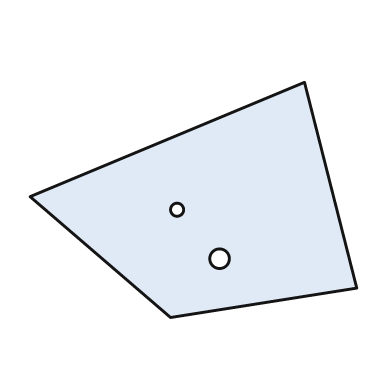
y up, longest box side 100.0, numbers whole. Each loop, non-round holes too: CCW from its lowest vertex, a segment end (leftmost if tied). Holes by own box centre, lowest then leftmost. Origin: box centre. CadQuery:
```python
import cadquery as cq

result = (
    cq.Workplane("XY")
    .moveTo(-7.0, -36.0)
    .lineTo(50.0, -27.0)
    .lineTo(34.0, 36.0)
    .lineTo(-50.0, 1.0)
    .close()
    .moveTo(8.0, -18.0)
    .circle(3.0)
    .moveTo(-5.0, -3.0)
    .circle(2.0)
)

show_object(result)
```